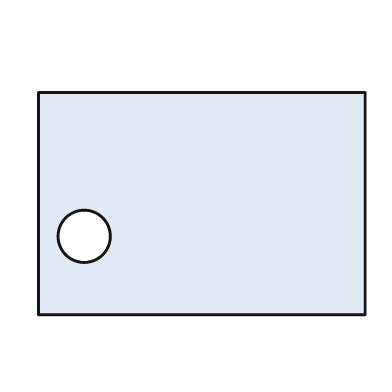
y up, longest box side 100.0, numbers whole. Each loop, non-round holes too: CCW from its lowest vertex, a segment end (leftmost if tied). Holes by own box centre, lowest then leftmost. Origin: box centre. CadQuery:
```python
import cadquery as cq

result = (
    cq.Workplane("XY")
    .moveTo(-50.0, -34.0)
    .lineTo(50.0, -34.0)
    .lineTo(50.0, 34.0)
    .lineTo(-50.0, 34.0)
    .close()
    .moveTo(-36.0, -10.0)
    .circle(8.0)
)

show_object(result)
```